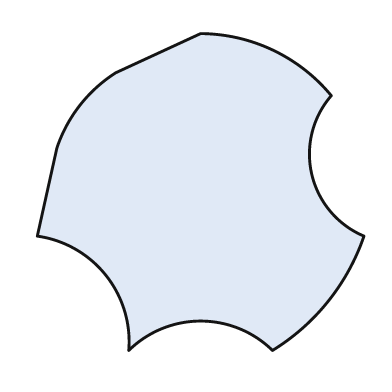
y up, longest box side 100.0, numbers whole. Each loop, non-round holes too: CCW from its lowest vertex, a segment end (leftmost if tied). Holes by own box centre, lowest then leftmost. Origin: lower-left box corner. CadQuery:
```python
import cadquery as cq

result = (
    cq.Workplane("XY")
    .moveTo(28.0, 0.0)
    .threePointArc((50.0, 9.0), (72.0, 0.0))
    .threePointArc((89.0, 15.0), (100.0, 35.0))
    .threePointArc((84.0, 54.0), (90.0, 78.0))
    .threePointArc((72.0, 92.0), (50.0, 97.0))
    .lineTo(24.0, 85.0)
    .threePointArc((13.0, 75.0), (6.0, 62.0))
    .lineTo(0.0, 35.0)
    .threePointArc((21.0, 23.0), (28.0, 0.0))
    .close()
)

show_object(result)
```